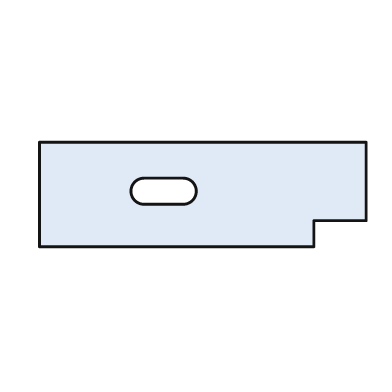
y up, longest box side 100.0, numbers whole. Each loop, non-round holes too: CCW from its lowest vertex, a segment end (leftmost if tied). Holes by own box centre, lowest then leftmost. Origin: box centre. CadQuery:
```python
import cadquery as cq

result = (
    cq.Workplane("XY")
    .moveTo(-50.0, -16.0)
    .lineTo(34.0, -16.0)
    .lineTo(34.0, -8.0)
    .lineTo(50.0, -8.0)
    .lineTo(50.0, 16.0)
    .lineTo(-50.0, 16.0)
    .close()
    .moveTo(-18.0, -3.0)
    .lineTo(-6.0, -3.0)
    .threePointArc((-2.0, 1.0), (-6.0, 5.0))
    .lineTo(-18.0, 5.0)
    .threePointArc((-22.0, 1.0), (-18.0, -3.0))
    .close()
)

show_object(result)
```